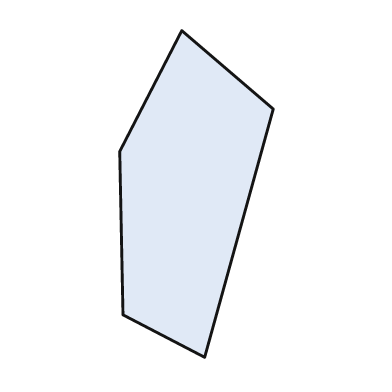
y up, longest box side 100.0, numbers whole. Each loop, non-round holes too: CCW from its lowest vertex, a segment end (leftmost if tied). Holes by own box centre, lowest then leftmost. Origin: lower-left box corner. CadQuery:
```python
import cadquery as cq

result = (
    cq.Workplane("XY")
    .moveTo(26.0, 0.0)
    .lineTo(47.0, 76.0)
    .lineTo(19.0, 100.0)
    .lineTo(0.0, 63.0)
    .lineTo(1.0, 13.0)
    .close()
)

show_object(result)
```